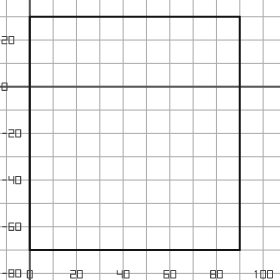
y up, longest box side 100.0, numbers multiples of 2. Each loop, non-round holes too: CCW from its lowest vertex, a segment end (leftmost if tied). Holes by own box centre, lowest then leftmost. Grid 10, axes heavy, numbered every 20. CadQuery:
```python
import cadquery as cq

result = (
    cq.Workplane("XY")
    .moveTo(0.0, -70.0)
    .lineTo(90.0, -70.0)
    .lineTo(90.0, 30.0)
    .lineTo(0.0, 30.0)
    .close()
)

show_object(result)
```